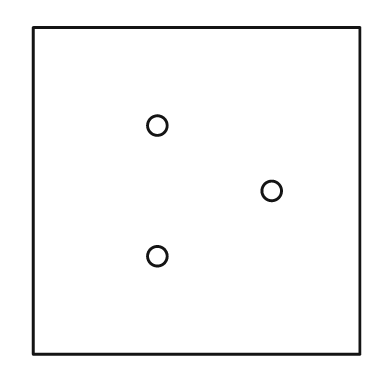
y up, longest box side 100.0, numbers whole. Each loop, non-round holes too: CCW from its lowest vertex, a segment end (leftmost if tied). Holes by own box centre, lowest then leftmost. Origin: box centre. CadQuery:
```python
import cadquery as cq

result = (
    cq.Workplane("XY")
    .moveTo(-50.0, -50.0)
    .lineTo(50.0, -50.0)
    .lineTo(50.0, 50.0)
    .lineTo(-50.0, 50.0)
    .close()
    .moveTo(-12.0, -20.0)
    .circle(3.0)
    .moveTo(23.0, 0.0)
    .circle(3.0)
    .moveTo(-12.0, 20.0)
    .circle(3.0)
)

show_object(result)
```